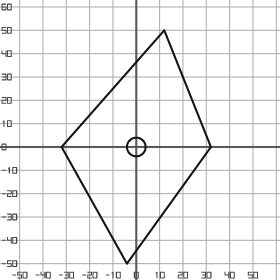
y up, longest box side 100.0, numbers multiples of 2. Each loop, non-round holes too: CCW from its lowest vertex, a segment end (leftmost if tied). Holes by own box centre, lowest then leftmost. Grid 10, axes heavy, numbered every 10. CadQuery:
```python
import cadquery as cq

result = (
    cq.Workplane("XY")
    .moveTo(-4.0, -50.0)
    .lineTo(32.0, 0.0)
    .lineTo(12.0, 50.0)
    .lineTo(-32.0, 0.0)
    .close()
    .moveTo(0.0, 0.0)
    .circle(4.0)
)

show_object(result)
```